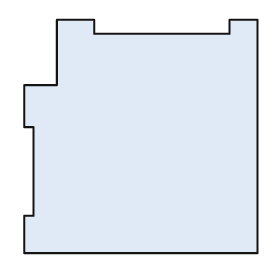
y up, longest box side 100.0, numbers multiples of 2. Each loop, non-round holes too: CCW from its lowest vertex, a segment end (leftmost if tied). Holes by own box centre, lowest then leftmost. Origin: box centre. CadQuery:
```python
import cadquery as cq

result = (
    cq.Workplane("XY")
    .moveTo(-50.0, -50.0)
    .lineTo(50.0, -50.0)
    .lineTo(50.0, 50.0)
    .lineTo(38.0, 50.0)
    .lineTo(38.0, 44.0)
    .lineTo(-20.0, 44.0)
    .lineTo(-20.0, 50.0)
    .lineTo(-36.0, 50.0)
    .lineTo(-36.0, 22.0)
    .lineTo(-50.0, 22.0)
    .lineTo(-50.0, 4.0)
    .lineTo(-46.0, 4.0)
    .lineTo(-46.0, -34.0)
    .lineTo(-50.0, -34.0)
    .close()
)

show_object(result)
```